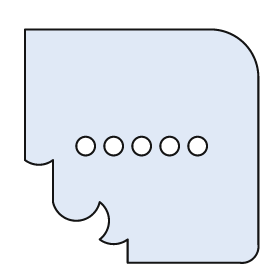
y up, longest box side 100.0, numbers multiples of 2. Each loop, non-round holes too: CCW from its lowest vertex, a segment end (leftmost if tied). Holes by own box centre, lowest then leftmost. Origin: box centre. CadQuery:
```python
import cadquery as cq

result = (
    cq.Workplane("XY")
    .moveTo(-6.0, -50.0)
    .lineTo(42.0, -50.0)
    .threePointArc((48.0, -48.0), (50.0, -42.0))
    .lineTo(50.0, 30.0)
    .threePointArc((44.0, 44.0), (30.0, 50.0))
    .lineTo(-50.0, 50.0)
    .lineTo(-50.0, -6.0)
    .threePointArc((-44.0, -8.0), (-38.0, -6.0))
    .lineTo(-38.0, -24.0)
    .threePointArc((-28.0, -32.0), (-18.0, -24.0))
    .threePointArc((-14.0, -32.0), (-18.0, -40.0))
    .threePointArc((-12.0, -42.0), (-6.0, -40.0))
    .close()
    .moveTo(-24.0, 0.0)
    .circle(4.0)
    .moveTo(-12.0, 0.0)
    .circle(4.0)
    .moveTo(0.0, 0.0)
    .circle(4.0)
    .moveTo(12.0, 0.0)
    .circle(4.0)
    .moveTo(24.0, 0.0)
    .circle(4.0)
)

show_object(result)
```